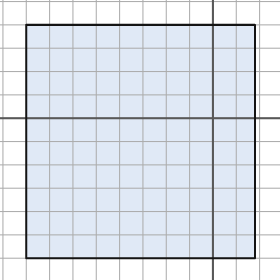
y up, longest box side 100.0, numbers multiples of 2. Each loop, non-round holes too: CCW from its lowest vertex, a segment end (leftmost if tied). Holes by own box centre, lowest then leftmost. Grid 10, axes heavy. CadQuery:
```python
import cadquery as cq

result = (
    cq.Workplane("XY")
    .moveTo(-80.0, -60.0)
    .lineTo(18.0, -60.0)
    .lineTo(18.0, 40.0)
    .lineTo(-80.0, 40.0)
    .close()
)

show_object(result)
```